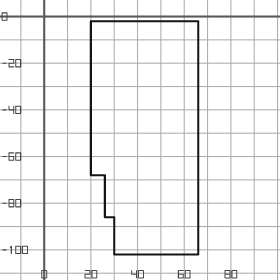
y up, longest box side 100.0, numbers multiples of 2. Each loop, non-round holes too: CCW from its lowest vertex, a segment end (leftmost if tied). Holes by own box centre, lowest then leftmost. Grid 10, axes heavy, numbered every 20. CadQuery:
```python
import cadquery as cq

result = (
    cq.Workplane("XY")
    .moveTo(30.0, -102.0)
    .lineTo(66.0, -102.0)
    .lineTo(66.0, -2.0)
    .lineTo(20.0, -2.0)
    .lineTo(20.0, -68.0)
    .lineTo(26.0, -68.0)
    .lineTo(26.0, -86.0)
    .lineTo(30.0, -86.0)
    .close()
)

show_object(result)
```